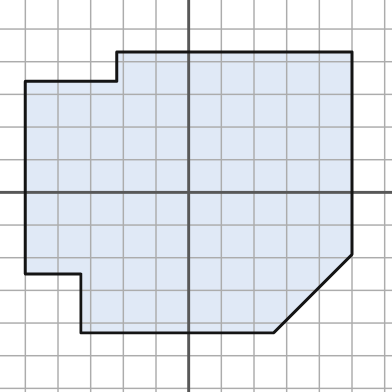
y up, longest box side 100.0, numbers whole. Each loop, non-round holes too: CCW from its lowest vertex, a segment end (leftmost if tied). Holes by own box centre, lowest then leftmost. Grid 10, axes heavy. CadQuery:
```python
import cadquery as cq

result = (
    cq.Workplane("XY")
    .moveTo(-33.0, -43.0)
    .lineTo(26.0, -43.0)
    .lineTo(50.0, -19.0)
    .lineTo(50.0, 43.0)
    .lineTo(-22.0, 43.0)
    .lineTo(-22.0, 34.0)
    .lineTo(-50.0, 34.0)
    .lineTo(-50.0, -25.0)
    .lineTo(-33.0, -25.0)
    .close()
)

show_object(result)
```